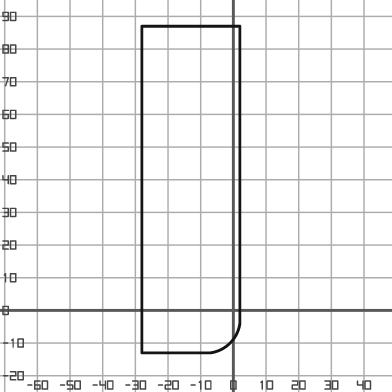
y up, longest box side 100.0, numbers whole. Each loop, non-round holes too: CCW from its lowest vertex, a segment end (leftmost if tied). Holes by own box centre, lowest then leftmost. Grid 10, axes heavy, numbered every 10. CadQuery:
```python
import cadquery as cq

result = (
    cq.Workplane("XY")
    .moveTo(-28.0, -13.0)
    .lineTo(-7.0, -13.0)
    .threePointArc((-1.0, -10.0), (2.0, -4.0))
    .lineTo(2.0, 87.0)
    .lineTo(-28.0, 87.0)
    .close()
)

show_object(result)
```